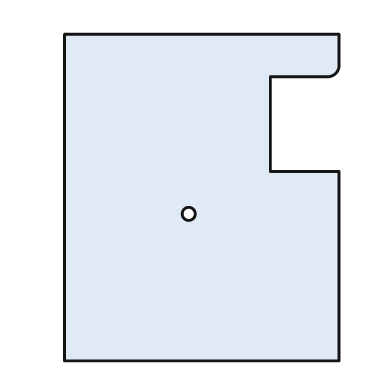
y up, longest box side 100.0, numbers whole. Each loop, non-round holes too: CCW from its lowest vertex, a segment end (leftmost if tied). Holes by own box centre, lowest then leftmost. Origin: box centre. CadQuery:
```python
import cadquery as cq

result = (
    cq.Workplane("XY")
    .moveTo(-42.0, -50.0)
    .lineTo(42.0, -50.0)
    .lineTo(42.0, 8.0)
    .lineTo(21.0, 8.0)
    .lineTo(21.0, 37.0)
    .lineTo(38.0, 37.0)
    .threePointArc((41.0, 38.0), (42.0, 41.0))
    .lineTo(42.0, 50.0)
    .lineTo(-42.0, 50.0)
    .close()
    .moveTo(-4.0, -5.0)
    .circle(2.0)
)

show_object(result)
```